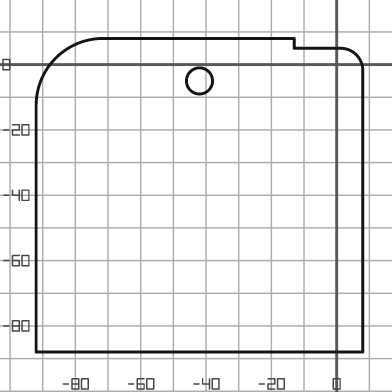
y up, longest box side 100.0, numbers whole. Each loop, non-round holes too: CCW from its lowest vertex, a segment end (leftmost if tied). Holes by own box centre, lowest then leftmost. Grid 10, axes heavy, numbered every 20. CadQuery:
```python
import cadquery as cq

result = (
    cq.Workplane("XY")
    .moveTo(-92.0, -88.0)
    .lineTo(8.0, -88.0)
    .lineTo(8.0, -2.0)
    .threePointArc((6.0, 3.0), (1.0, 5.0))
    .lineTo(-13.0, 5.0)
    .lineTo(-13.0, 8.0)
    .lineTo(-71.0, 8.0)
    .threePointArc((-86.0, 2.0), (-92.0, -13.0))
    .close()
    .moveTo(-42.0, -5.0)
    .circle(4.0)
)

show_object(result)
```